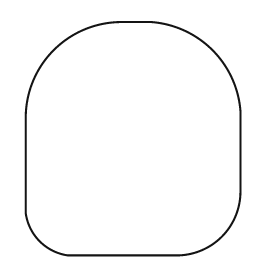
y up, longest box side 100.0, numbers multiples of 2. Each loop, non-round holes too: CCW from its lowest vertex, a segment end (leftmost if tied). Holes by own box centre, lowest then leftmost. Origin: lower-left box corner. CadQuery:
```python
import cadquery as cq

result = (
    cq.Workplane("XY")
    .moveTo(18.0, 0.0)
    .lineTo(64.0, 0.0)
    .threePointArc((84.0, 8.0), (92.0, 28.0))
    .lineTo(92.0, 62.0)
    .threePointArc((80.0, 88.0), (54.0, 100.0))
    .lineTo(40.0, 100.0)
    .threePointArc((12.0, 88.0), (0.0, 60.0))
    .lineTo(0.0, 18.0)
    .threePointArc((6.0, 6.0), (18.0, 0.0))
    .close()
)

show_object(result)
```